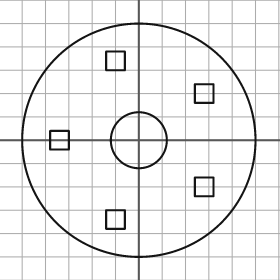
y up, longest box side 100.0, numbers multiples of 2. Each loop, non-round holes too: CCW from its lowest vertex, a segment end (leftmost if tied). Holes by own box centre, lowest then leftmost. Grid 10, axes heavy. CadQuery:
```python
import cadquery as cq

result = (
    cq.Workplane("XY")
    .moveTo(0.0, 0.0)
    .circle(50.0)
    .moveTo(-14.0, -38.0)
    .lineTo(-6.0, -38.0)
    .lineTo(-6.0, -30.0)
    .lineTo(-14.0, -30.0)
    .close()
    .moveTo(24.0, -24.0)
    .lineTo(32.0, -24.0)
    .lineTo(32.0, -16.0)
    .lineTo(24.0, -16.0)
    .close()
    .moveTo(-38.0, -4.0)
    .lineTo(-30.0, -4.0)
    .lineTo(-30.0, 4.0)
    .lineTo(-38.0, 4.0)
    .close()
    .moveTo(0.0, 0.0)
    .circle(12.0)
    .moveTo(24.0, 16.0)
    .lineTo(32.0, 16.0)
    .lineTo(32.0, 24.0)
    .lineTo(24.0, 24.0)
    .close()
    .moveTo(-14.0, 30.0)
    .lineTo(-6.0, 30.0)
    .lineTo(-6.0, 38.0)
    .lineTo(-14.0, 38.0)
    .close()
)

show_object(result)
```